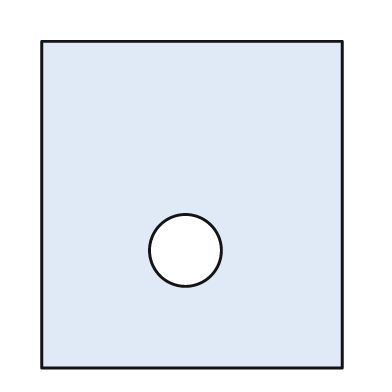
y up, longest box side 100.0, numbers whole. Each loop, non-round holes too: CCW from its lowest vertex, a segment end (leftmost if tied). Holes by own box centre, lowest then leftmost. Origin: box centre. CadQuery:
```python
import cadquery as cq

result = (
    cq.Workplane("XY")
    .moveTo(-46.0, -50.0)
    .lineTo(46.0, -50.0)
    .lineTo(46.0, 50.0)
    .lineTo(-46.0, 50.0)
    .close()
    .moveTo(-2.0, -14.0)
    .circle(11.0)
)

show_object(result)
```